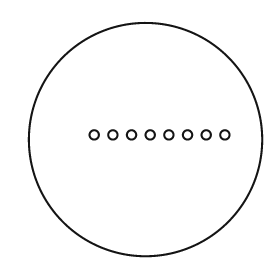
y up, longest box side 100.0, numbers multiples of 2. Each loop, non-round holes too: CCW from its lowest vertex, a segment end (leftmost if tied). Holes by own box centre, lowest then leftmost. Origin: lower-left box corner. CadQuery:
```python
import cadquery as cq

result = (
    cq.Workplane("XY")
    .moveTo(50.0, 50.0)
    .circle(50.0)
    .moveTo(28.0, 52.0)
    .circle(2.0)
    .moveTo(36.0, 52.0)
    .circle(2.0)
    .moveTo(44.0, 52.0)
    .circle(2.0)
    .moveTo(52.0, 52.0)
    .circle(2.0)
    .moveTo(60.0, 52.0)
    .circle(2.0)
    .moveTo(68.0, 52.0)
    .circle(2.0)
    .moveTo(76.0, 52.0)
    .circle(2.0)
    .moveTo(84.0, 52.0)
    .circle(2.0)
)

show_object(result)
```